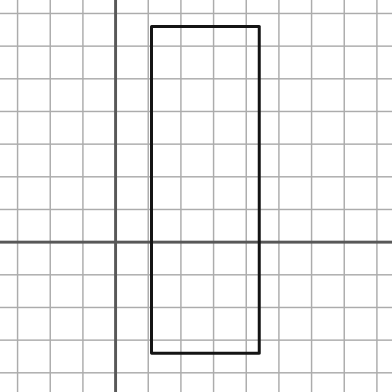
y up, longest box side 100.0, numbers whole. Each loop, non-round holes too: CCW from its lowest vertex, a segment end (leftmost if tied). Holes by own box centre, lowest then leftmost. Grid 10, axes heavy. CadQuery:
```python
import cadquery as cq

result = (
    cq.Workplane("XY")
    .moveTo(11.0, -34.0)
    .lineTo(44.0, -34.0)
    .lineTo(44.0, 66.0)
    .lineTo(11.0, 66.0)
    .close()
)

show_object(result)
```